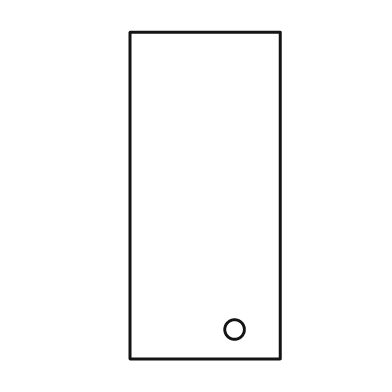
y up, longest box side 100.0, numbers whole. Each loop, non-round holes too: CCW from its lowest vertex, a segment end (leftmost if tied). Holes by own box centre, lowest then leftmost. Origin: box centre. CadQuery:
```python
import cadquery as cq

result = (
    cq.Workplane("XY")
    .moveTo(-23.0, -50.0)
    .lineTo(23.0, -50.0)
    .lineTo(23.0, 50.0)
    .lineTo(-23.0, 50.0)
    .close()
    .moveTo(9.0, -41.0)
    .circle(3.0)
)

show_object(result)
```